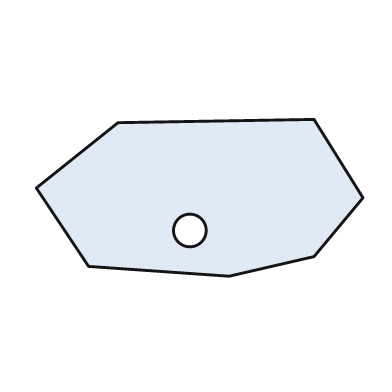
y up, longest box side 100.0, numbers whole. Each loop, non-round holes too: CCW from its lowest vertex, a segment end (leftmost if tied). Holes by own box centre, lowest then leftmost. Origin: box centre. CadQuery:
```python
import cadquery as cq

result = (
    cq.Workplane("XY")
    .moveTo(9.0, -24.0)
    .lineTo(35.0, -18.0)
    .lineTo(50.0, 0.0)
    .lineTo(35.0, 24.0)
    .lineTo(-25.0, 23.0)
    .lineTo(-50.0, 3.0)
    .lineTo(-34.0, -21.0)
    .close()
    .moveTo(-3.0, -10.0)
    .circle(5.0)
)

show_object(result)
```